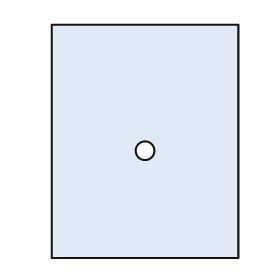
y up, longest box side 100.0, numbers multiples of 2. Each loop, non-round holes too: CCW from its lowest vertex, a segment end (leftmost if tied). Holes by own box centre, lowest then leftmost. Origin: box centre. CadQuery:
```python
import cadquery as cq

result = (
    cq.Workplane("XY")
    .moveTo(-40.0, -50.0)
    .lineTo(40.0, -50.0)
    .lineTo(40.0, 50.0)
    .lineTo(-40.0, 50.0)
    .close()
    .moveTo(0.0, -4.0)
    .circle(4.0)
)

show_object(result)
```